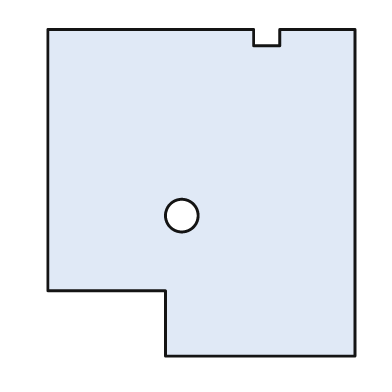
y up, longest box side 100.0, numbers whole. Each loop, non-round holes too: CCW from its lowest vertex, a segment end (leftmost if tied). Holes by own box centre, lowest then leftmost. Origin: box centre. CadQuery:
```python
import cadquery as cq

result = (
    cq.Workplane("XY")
    .moveTo(-11.0, -50.0)
    .lineTo(47.0, -50.0)
    .lineTo(47.0, 50.0)
    .lineTo(24.0, 50.0)
    .lineTo(24.0, 45.0)
    .lineTo(16.0, 45.0)
    .lineTo(16.0, 50.0)
    .lineTo(-47.0, 50.0)
    .lineTo(-47.0, -30.0)
    .lineTo(-11.0, -30.0)
    .close()
    .moveTo(-6.0, -7.0)
    .circle(5.0)
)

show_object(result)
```